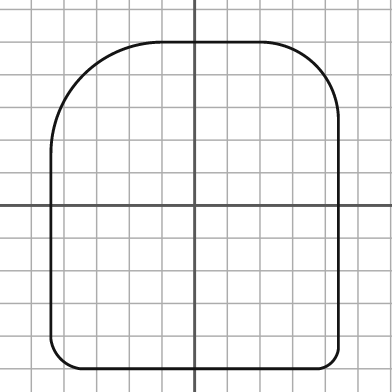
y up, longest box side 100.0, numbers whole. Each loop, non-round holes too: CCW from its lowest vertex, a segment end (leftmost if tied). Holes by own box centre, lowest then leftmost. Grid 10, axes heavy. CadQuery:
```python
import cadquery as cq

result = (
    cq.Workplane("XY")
    .moveTo(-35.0, -50.0)
    .lineTo(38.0, -50.0)
    .threePointArc((42.0, -48.0), (44.0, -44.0))
    .lineTo(44.0, 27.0)
    .threePointArc((37.0, 43.0), (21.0, 50.0))
    .lineTo(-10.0, 50.0)
    .threePointArc((-34.0, 40.0), (-44.0, 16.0))
    .lineTo(-44.0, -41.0)
    .threePointArc((-41.0, -47.0), (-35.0, -50.0))
    .close()
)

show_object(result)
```